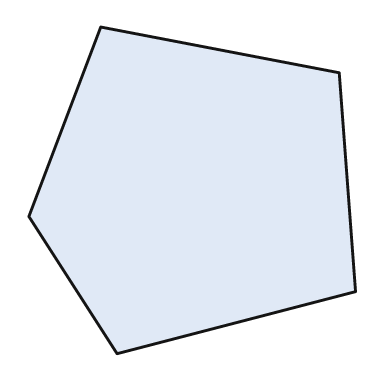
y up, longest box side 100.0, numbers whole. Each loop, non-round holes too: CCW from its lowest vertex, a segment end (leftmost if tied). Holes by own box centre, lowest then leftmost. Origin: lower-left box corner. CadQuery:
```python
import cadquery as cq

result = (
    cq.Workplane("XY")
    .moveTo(27.0, 0.0)
    .lineTo(100.0, 19.0)
    .lineTo(95.0, 86.0)
    .lineTo(22.0, 100.0)
    .lineTo(0.0, 42.0)
    .close()
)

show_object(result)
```